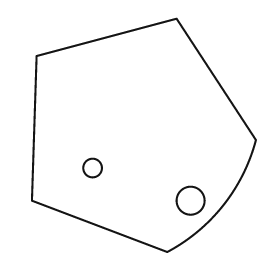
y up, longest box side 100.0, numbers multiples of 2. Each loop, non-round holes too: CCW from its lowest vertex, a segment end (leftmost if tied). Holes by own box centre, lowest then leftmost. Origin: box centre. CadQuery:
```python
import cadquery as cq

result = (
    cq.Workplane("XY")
    .moveTo(10.0, -50.0)
    .threePointArc((34.0, -30.0), (48.0, -2.0))
    .lineTo(14.0, 50.0)
    .lineTo(-46.0, 34.0)
    .lineTo(-48.0, -28.0)
    .close()
    .moveTo(20.0, -28.0)
    .circle(6.0)
    .moveTo(-22.0, -14.0)
    .circle(4.0)
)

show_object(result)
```